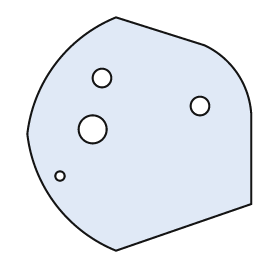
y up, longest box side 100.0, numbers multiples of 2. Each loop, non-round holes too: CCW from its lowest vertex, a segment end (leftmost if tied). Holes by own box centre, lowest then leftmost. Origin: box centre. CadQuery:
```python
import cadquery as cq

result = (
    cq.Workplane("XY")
    .moveTo(-10.0, -50.0)
    .lineTo(48.0, -30.0)
    .lineTo(48.0, 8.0)
    .threePointArc((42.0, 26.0), (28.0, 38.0))
    .lineTo(-10.0, 50.0)
    .threePointArc((-36.0, 30.0), (-48.0, 0.0))
    .threePointArc((-36.0, -30.0), (-10.0, -50.0))
    .close()
    .moveTo(-34.0, -18.0)
    .circle(2.0)
    .moveTo(-20.0, 2.0)
    .circle(6.0)
    .moveTo(26.0, 12.0)
    .circle(4.0)
    .moveTo(-16.0, 24.0)
    .circle(4.0)
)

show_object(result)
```